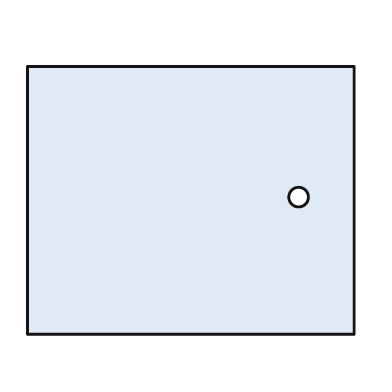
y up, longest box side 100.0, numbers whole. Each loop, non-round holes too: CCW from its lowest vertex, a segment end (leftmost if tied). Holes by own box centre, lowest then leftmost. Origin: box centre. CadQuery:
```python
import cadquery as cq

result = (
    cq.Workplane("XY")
    .moveTo(-50.0, -41.0)
    .lineTo(50.0, -41.0)
    .lineTo(50.0, 41.0)
    .lineTo(-50.0, 41.0)
    .close()
    .moveTo(33.0, 1.0)
    .circle(3.0)
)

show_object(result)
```